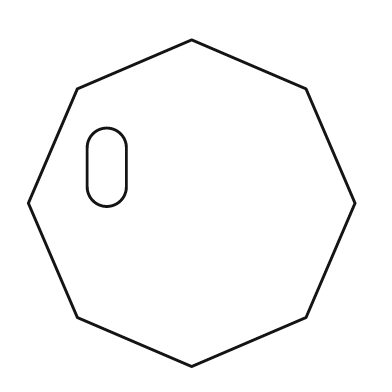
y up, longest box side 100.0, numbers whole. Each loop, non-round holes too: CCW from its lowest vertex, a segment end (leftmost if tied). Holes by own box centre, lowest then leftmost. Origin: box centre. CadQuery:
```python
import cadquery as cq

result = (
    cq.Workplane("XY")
    .moveTo(0.0, -50.0)
    .lineTo(35.0, -35.0)
    .lineTo(50.0, 0.0)
    .lineTo(35.0, 35.0)
    .lineTo(0.0, 50.0)
    .lineTo(-35.0, 35.0)
    .lineTo(-50.0, 0.0)
    .lineTo(-35.0, -35.0)
    .close()
    .moveTo(-32.0, 5.0)
    .threePointArc((-26.0, -1.0), (-20.0, 5.0))
    .lineTo(-20.0, 17.0)
    .threePointArc((-26.0, 23.0), (-32.0, 17.0))
    .close()
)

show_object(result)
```